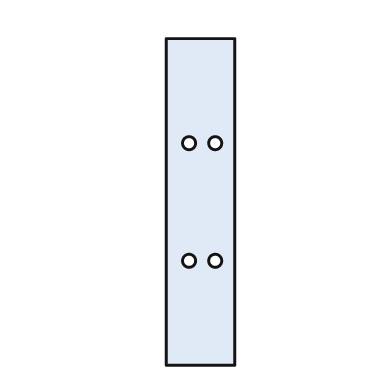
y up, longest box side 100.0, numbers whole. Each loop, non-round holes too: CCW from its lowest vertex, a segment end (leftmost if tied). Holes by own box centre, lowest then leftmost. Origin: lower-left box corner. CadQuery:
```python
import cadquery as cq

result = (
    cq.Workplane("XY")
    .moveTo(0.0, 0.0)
    .lineTo(21.0, 0.0)
    .lineTo(21.0, 100.0)
    .lineTo(0.0, 100.0)
    .close()
    .moveTo(7.0, 32.0)
    .circle(2.0)
    .moveTo(15.0, 32.0)
    .circle(2.0)
    .moveTo(7.0, 68.0)
    .circle(2.0)
    .moveTo(15.0, 68.0)
    .circle(2.0)
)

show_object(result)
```